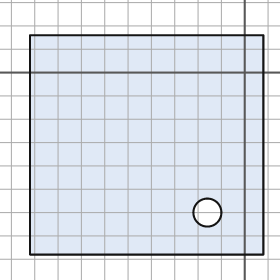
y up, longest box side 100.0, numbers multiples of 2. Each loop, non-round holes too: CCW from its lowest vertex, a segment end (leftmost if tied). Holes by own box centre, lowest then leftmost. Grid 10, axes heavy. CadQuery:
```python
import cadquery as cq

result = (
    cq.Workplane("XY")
    .moveTo(-92.0, -78.0)
    .lineTo(8.0, -78.0)
    .lineTo(8.0, 16.0)
    .lineTo(-92.0, 16.0)
    .close()
    .moveTo(-16.0, -60.0)
    .circle(6.0)
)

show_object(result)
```